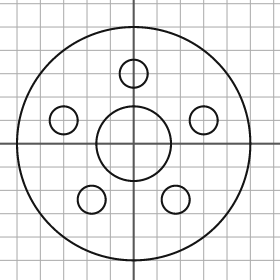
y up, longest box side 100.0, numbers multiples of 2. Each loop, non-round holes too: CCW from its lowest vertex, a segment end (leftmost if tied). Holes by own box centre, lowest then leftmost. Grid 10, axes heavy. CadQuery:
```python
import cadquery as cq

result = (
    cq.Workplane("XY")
    .moveTo(0.0, 0.0)
    .circle(50.0)
    .moveTo(-18.0, -24.0)
    .circle(6.0)
    .moveTo(18.0, -24.0)
    .circle(6.0)
    .moveTo(0.0, 0.0)
    .circle(16.0)
    .moveTo(-30.0, 10.0)
    .circle(6.0)
    .moveTo(30.0, 10.0)
    .circle(6.0)
    .moveTo(0.0, 30.0)
    .circle(6.0)
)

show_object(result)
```